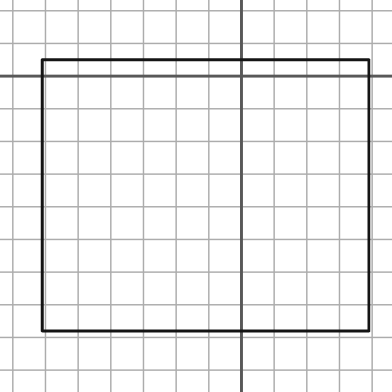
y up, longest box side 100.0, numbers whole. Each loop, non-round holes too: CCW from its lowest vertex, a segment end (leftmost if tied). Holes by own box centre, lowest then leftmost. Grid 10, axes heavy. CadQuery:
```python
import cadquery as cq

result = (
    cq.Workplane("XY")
    .moveTo(-61.0, -78.0)
    .lineTo(39.0, -78.0)
    .lineTo(39.0, 5.0)
    .lineTo(-61.0, 5.0)
    .close()
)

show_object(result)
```